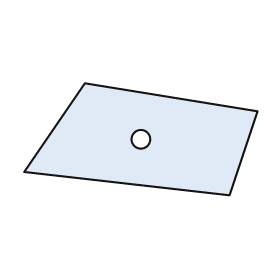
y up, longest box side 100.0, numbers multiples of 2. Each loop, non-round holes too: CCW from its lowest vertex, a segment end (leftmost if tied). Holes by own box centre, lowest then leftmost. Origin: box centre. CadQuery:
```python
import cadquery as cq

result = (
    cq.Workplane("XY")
    .moveTo(38.0, -24.0)
    .lineTo(50.0, 12.0)
    .lineTo(-24.0, 24.0)
    .lineTo(-50.0, -14.0)
    .close()
    .moveTo(0.0, 0.0)
    .circle(4.0)
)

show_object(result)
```